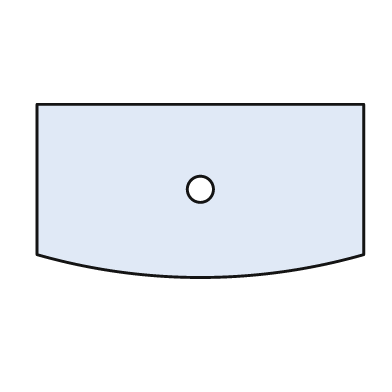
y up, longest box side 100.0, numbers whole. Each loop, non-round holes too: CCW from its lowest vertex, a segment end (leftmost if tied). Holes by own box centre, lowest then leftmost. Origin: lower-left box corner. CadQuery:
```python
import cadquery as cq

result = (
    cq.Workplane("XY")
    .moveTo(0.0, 7.0)
    .threePointArc((50.0, 0.0), (100.0, 7.0))
    .lineTo(100.0, 53.0)
    .lineTo(0.0, 53.0)
    .close()
    .moveTo(50.0, 27.0)
    .circle(4.0)
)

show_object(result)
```